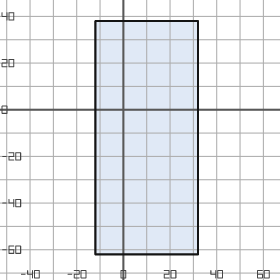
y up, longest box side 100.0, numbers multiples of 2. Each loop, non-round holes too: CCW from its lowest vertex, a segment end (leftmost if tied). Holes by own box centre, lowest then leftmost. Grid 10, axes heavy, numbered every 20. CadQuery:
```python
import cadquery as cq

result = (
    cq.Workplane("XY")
    .moveTo(-12.0, -62.0)
    .lineTo(32.0, -62.0)
    .lineTo(32.0, 38.0)
    .lineTo(-12.0, 38.0)
    .close()
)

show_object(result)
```